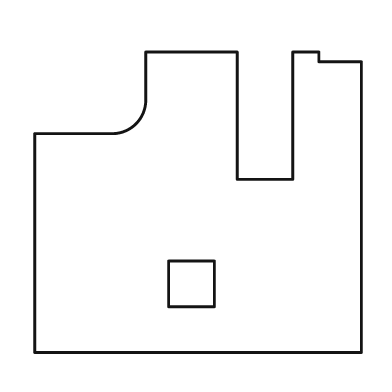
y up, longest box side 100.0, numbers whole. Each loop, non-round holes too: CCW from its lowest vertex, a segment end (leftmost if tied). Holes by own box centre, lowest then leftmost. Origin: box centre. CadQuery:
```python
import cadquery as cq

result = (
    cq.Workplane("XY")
    .moveTo(-50.0, -46.0)
    .lineTo(50.0, -46.0)
    .lineTo(50.0, 43.0)
    .lineTo(37.0, 43.0)
    .lineTo(37.0, 46.0)
    .lineTo(29.0, 46.0)
    .lineTo(29.0, 7.0)
    .lineTo(12.0, 7.0)
    .lineTo(12.0, 46.0)
    .lineTo(-16.0, 46.0)
    .lineTo(-16.0, 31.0)
    .threePointArc((-19.0, 24.0), (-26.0, 21.0))
    .lineTo(-50.0, 21.0)
    .close()
    .moveTo(-9.0, -32.0)
    .lineTo(5.0, -32.0)
    .lineTo(5.0, -18.0)
    .lineTo(-9.0, -18.0)
    .close()
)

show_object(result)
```